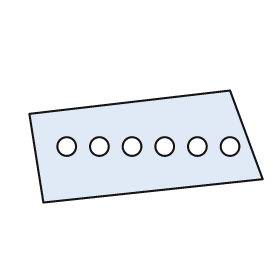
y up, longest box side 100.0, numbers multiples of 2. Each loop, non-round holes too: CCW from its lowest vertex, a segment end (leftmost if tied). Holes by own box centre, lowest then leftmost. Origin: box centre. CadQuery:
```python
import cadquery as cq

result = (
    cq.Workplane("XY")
    .moveTo(-44.0, -24.0)
    .lineTo(50.0, -14.0)
    .lineTo(36.0, 24.0)
    .lineTo(-50.0, 14.0)
    .close()
    .moveTo(-34.0, 0.0)
    .circle(4.0)
    .moveTo(-20.0, 0.0)
    .circle(4.0)
    .moveTo(-6.0, 0.0)
    .circle(4.0)
    .moveTo(8.0, 0.0)
    .circle(4.0)
    .moveTo(22.0, 0.0)
    .circle(4.0)
    .moveTo(36.0, 0.0)
    .circle(4.0)
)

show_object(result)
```